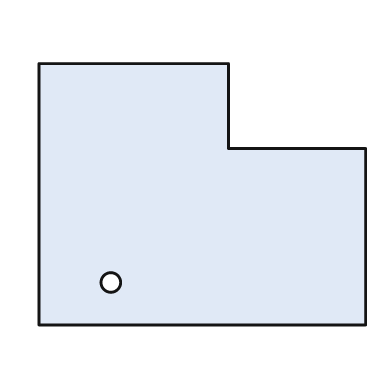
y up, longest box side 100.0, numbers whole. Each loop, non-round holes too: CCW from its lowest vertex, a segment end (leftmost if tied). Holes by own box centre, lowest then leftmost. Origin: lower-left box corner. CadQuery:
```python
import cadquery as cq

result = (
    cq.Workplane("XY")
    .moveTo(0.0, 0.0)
    .lineTo(100.0, 0.0)
    .lineTo(100.0, 54.0)
    .lineTo(58.0, 54.0)
    .lineTo(58.0, 80.0)
    .lineTo(0.0, 80.0)
    .close()
    .moveTo(22.0, 13.0)
    .circle(3.0)
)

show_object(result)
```